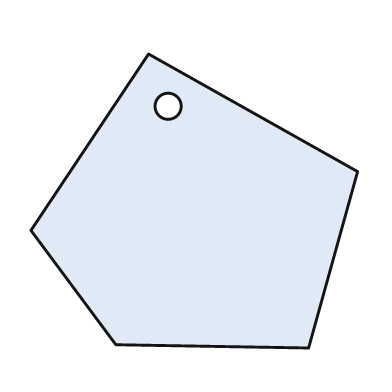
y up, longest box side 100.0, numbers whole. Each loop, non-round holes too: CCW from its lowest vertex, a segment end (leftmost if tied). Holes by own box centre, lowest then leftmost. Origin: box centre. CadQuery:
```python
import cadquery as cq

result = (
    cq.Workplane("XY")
    .moveTo(35.0, -45.0)
    .lineTo(50.0, 9.0)
    .lineTo(-14.0, 45.0)
    .lineTo(-50.0, -9.0)
    .lineTo(-24.0, -44.0)
    .close()
    .moveTo(-8.0, 29.0)
    .circle(4.0)
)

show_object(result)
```